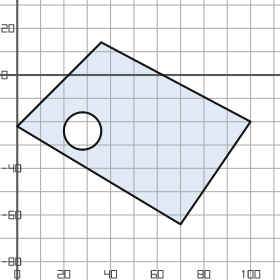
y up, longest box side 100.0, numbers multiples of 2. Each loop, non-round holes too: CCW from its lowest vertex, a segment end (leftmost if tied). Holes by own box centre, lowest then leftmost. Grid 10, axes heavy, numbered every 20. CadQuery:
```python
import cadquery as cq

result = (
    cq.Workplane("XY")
    .moveTo(70.0, -64.0)
    .lineTo(100.0, -20.0)
    .lineTo(36.0, 14.0)
    .lineTo(0.0, -22.0)
    .close()
    .moveTo(28.0, -24.0)
    .circle(8.0)
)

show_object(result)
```